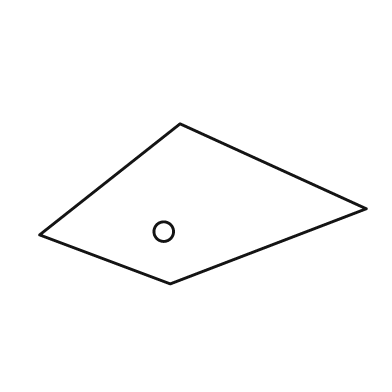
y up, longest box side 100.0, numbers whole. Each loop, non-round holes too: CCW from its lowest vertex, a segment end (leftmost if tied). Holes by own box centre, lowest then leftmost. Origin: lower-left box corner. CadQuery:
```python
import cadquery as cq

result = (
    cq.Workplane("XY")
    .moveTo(40.0, 0.0)
    .lineTo(100.0, 23.0)
    .lineTo(43.0, 49.0)
    .lineTo(0.0, 15.0)
    .close()
    .moveTo(38.0, 16.0)
    .circle(3.0)
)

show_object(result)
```